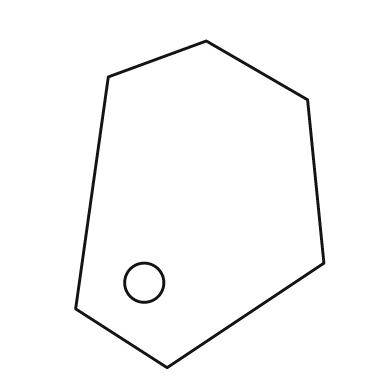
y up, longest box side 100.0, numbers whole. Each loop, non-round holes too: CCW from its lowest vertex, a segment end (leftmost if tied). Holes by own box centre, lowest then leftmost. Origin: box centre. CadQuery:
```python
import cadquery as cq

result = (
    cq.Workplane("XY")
    .moveTo(-10.0, -50.0)
    .lineTo(38.0, -18.0)
    .lineTo(33.0, 32.0)
    .lineTo(2.0, 50.0)
    .lineTo(-28.0, 39.0)
    .lineTo(-38.0, -32.0)
    .close()
    .moveTo(-17.0, -24.0)
    .circle(6.0)
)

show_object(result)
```